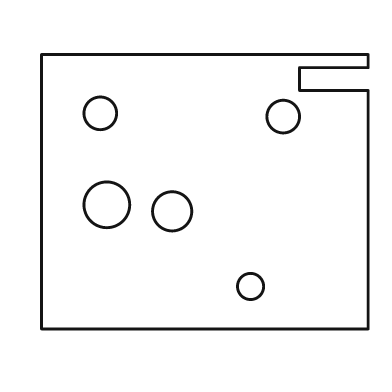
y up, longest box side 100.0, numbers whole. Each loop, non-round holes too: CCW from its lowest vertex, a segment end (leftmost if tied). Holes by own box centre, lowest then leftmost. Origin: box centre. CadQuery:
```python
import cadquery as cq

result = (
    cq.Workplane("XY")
    .moveTo(-50.0, -42.0)
    .lineTo(50.0, -42.0)
    .lineTo(50.0, 31.0)
    .lineTo(29.0, 31.0)
    .lineTo(29.0, 38.0)
    .lineTo(50.0, 38.0)
    .lineTo(50.0, 42.0)
    .lineTo(-50.0, 42.0)
    .close()
    .moveTo(14.0, -29.0)
    .circle(4.0)
    .moveTo(-10.0, -6.0)
    .circle(6.0)
    .moveTo(-30.0, -4.0)
    .circle(7.0)
    .moveTo(24.0, 23.0)
    .circle(5.0)
    .moveTo(-32.0, 24.0)
    .circle(5.0)
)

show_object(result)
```